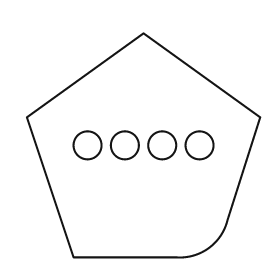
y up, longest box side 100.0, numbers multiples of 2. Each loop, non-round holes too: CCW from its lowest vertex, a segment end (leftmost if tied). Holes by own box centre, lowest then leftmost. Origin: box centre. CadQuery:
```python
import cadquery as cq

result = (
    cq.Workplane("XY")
    .moveTo(-30.0, -48.0)
    .lineTo(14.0, -48.0)
    .threePointArc((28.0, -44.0), (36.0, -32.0))
    .lineTo(50.0, 12.0)
    .lineTo(0.0, 48.0)
    .lineTo(-50.0, 12.0)
    .close()
    .moveTo(-24.0, 0.0)
    .circle(6.0)
    .moveTo(-8.0, 0.0)
    .circle(6.0)
    .moveTo(8.0, 0.0)
    .circle(6.0)
    .moveTo(24.0, 0.0)
    .circle(6.0)
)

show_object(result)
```